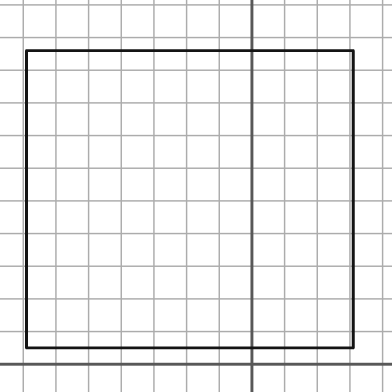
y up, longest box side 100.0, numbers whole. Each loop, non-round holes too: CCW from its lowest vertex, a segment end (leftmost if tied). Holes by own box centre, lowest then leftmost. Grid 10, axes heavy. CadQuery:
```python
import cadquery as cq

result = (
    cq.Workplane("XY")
    .moveTo(-69.0, 5.0)
    .lineTo(31.0, 5.0)
    .lineTo(31.0, 96.0)
    .lineTo(-69.0, 96.0)
    .close()
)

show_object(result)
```